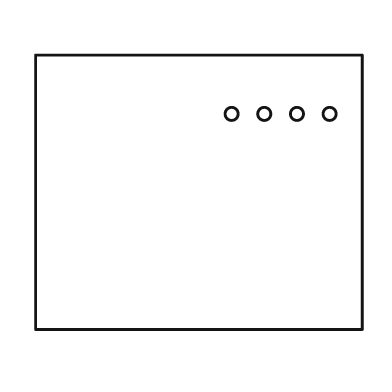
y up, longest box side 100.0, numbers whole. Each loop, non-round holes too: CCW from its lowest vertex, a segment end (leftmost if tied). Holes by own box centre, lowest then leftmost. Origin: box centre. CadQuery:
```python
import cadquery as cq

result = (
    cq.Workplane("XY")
    .moveTo(-50.0, -42.0)
    .lineTo(50.0, -42.0)
    .lineTo(50.0, 42.0)
    .lineTo(-50.0, 42.0)
    .close()
    .moveTo(10.0, 24.0)
    .circle(2.0)
    .moveTo(20.0, 24.0)
    .circle(2.0)
    .moveTo(30.0, 24.0)
    .circle(2.0)
    .moveTo(40.0, 24.0)
    .circle(2.0)
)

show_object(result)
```